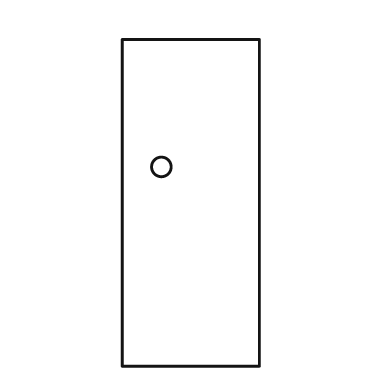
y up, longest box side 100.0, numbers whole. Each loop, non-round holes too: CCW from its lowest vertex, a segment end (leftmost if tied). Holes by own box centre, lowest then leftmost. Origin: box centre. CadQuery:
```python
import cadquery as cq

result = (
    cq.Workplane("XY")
    .moveTo(-21.0, -50.0)
    .lineTo(21.0, -50.0)
    .lineTo(21.0, 50.0)
    .lineTo(-21.0, 50.0)
    .close()
    .moveTo(-9.0, 11.0)
    .circle(3.0)
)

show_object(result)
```